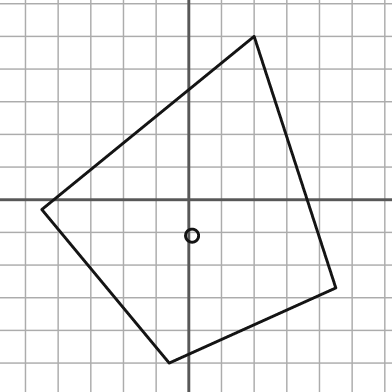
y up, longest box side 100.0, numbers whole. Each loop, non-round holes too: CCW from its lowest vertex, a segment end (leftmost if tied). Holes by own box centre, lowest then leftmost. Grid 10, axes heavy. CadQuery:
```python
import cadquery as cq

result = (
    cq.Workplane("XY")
    .moveTo(-6.0, -50.0)
    .lineTo(45.0, -27.0)
    .lineTo(20.0, 50.0)
    .lineTo(-45.0, -3.0)
    .close()
    .moveTo(1.0, -11.0)
    .circle(2.0)
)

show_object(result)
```